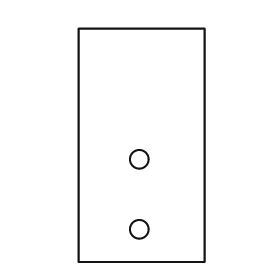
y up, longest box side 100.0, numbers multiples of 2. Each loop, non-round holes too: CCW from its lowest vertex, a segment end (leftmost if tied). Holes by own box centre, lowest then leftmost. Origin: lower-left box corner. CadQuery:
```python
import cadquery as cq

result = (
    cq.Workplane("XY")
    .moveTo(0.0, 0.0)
    .lineTo(54.0, 0.0)
    .lineTo(54.0, 100.0)
    .lineTo(0.0, 100.0)
    .close()
    .moveTo(26.0, 14.0)
    .circle(4.0)
    .moveTo(26.0, 44.0)
    .circle(4.0)
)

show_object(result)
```